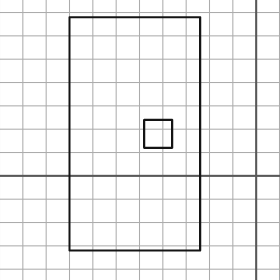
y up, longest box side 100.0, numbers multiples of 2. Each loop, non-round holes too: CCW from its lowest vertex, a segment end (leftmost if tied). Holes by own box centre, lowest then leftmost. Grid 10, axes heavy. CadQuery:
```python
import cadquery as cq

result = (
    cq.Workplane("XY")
    .moveTo(-80.0, -32.0)
    .lineTo(-24.0, -32.0)
    .lineTo(-24.0, 68.0)
    .lineTo(-80.0, 68.0)
    .close()
    .moveTo(-48.0, 12.0)
    .lineTo(-36.0, 12.0)
    .lineTo(-36.0, 24.0)
    .lineTo(-48.0, 24.0)
    .close()
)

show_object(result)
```